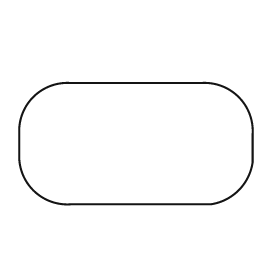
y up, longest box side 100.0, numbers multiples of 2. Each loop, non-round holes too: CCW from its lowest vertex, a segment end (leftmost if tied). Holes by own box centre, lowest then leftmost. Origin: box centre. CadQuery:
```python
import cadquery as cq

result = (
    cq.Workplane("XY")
    .moveTo(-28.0, -26.0)
    .lineTo(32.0, -26.0)
    .threePointArc((44.0, -20.0), (50.0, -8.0))
    .lineTo(50.0, 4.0)
    .threePointArc((44.0, 20.0), (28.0, 26.0))
    .lineTo(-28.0, 26.0)
    .threePointArc((-44.0, 20.0), (-50.0, 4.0))
    .lineTo(-50.0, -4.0)
    .threePointArc((-44.0, -20.0), (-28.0, -26.0))
    .close()
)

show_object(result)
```